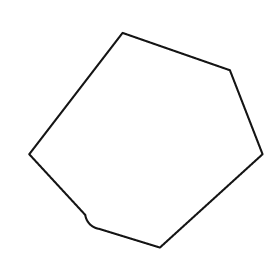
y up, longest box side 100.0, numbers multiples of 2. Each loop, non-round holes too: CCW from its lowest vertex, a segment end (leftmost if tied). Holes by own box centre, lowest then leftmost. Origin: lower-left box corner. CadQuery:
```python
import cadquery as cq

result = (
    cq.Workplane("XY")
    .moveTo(56.0, 0.0)
    .lineTo(100.0, 40.0)
    .lineTo(86.0, 76.0)
    .lineTo(40.0, 92.0)
    .lineTo(0.0, 40.0)
    .lineTo(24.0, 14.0)
    .threePointArc((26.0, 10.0), (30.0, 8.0))
    .close()
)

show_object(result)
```